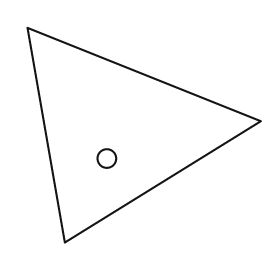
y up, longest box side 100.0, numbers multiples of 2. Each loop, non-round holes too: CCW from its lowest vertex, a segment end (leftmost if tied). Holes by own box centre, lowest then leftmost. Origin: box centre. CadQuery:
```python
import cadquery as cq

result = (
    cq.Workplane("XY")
    .moveTo(-34.0, -46.0)
    .lineTo(50.0, 6.0)
    .lineTo(-50.0, 46.0)
    .close()
    .moveTo(-16.0, -10.0)
    .circle(4.0)
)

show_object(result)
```